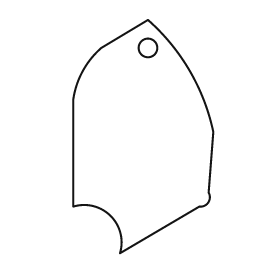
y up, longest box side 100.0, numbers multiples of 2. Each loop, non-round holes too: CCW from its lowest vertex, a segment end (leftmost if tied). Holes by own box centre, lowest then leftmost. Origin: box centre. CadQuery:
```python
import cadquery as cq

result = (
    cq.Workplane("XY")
    .moveTo(-10.0, -50.0)
    .lineTo(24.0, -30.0)
    .threePointArc((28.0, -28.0), (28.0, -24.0))
    .lineTo(30.0, 2.0)
    .threePointArc((20.0, 28.0), (2.0, 50.0))
    .lineTo(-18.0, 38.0)
    .threePointArc((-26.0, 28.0), (-30.0, 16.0))
    .lineTo(-30.0, -30.0)
    .threePointArc((-14.0, -34.0), (-10.0, -50.0))
    .close()
    .moveTo(2.0, 38.0)
    .circle(4.0)
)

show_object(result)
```